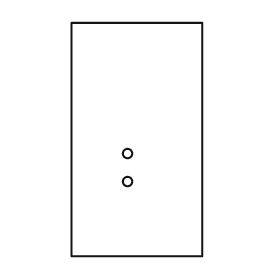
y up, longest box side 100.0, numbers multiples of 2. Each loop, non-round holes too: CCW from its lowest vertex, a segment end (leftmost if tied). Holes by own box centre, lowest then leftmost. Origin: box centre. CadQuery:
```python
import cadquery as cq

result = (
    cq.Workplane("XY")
    .moveTo(-28.0, -50.0)
    .lineTo(28.0, -50.0)
    .lineTo(28.0, 50.0)
    .lineTo(-28.0, 50.0)
    .close()
    .moveTo(-4.0, -18.0)
    .circle(2.0)
    .moveTo(-4.0, -6.0)
    .circle(2.0)
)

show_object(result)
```